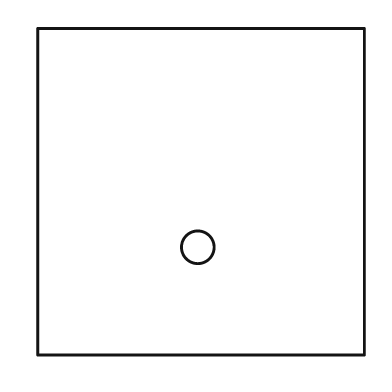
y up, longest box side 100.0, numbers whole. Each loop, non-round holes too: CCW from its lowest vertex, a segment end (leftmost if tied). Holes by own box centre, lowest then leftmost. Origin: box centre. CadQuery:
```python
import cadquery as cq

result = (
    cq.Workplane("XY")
    .moveTo(-50.0, -50.0)
    .lineTo(50.0, -50.0)
    .lineTo(50.0, 50.0)
    .lineTo(-50.0, 50.0)
    .close()
    .moveTo(-1.0, -17.0)
    .circle(5.0)
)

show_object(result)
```